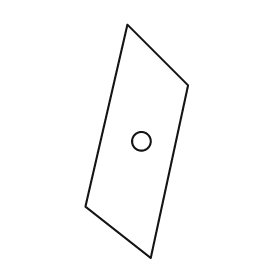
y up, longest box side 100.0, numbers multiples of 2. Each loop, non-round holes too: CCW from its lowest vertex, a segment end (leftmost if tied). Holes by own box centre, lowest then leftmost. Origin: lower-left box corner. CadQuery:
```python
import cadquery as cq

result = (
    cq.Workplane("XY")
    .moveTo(28.0, 0.0)
    .lineTo(44.0, 74.0)
    .lineTo(18.0, 100.0)
    .lineTo(0.0, 22.0)
    .close()
    .moveTo(24.0, 50.0)
    .circle(4.0)
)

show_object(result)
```